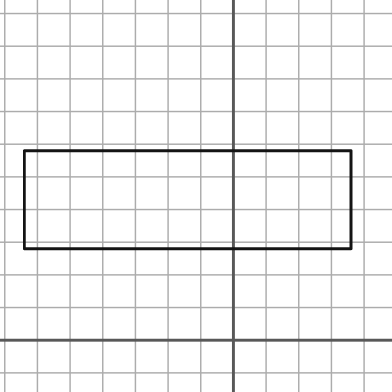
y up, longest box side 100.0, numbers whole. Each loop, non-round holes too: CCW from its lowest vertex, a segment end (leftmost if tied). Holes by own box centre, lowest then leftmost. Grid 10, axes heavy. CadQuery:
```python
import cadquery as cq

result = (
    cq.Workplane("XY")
    .moveTo(-64.0, 28.0)
    .lineTo(36.0, 28.0)
    .lineTo(36.0, 58.0)
    .lineTo(-64.0, 58.0)
    .close()
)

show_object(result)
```